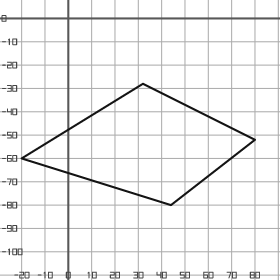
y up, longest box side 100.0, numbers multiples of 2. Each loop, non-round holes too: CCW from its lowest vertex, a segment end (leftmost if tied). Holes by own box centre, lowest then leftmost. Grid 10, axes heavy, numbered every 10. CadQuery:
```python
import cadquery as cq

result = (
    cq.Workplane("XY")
    .moveTo(44.0, -80.0)
    .lineTo(80.0, -52.0)
    .lineTo(32.0, -28.0)
    .lineTo(-20.0, -60.0)
    .close()
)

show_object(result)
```